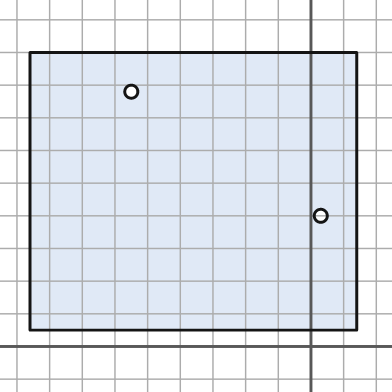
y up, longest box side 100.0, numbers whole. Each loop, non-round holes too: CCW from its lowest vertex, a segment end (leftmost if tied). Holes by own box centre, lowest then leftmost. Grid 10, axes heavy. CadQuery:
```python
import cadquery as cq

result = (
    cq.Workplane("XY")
    .moveTo(-86.0, 5.0)
    .lineTo(14.0, 5.0)
    .lineTo(14.0, 90.0)
    .lineTo(-86.0, 90.0)
    .close()
    .moveTo(3.0, 40.0)
    .circle(2.0)
    .moveTo(-55.0, 78.0)
    .circle(2.0)
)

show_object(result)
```